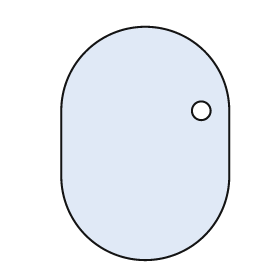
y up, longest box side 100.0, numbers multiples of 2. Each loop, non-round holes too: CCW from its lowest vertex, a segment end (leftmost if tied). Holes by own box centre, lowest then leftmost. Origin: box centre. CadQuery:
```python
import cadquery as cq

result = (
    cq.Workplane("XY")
    .moveTo(-36.0, -14.0)
    .threePointArc((0.0, -50.0), (36.0, -14.0))
    .lineTo(36.0, 14.0)
    .threePointArc((0.0, 50.0), (-36.0, 14.0))
    .close()
    .moveTo(24.0, 14.0)
    .circle(4.0)
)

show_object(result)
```